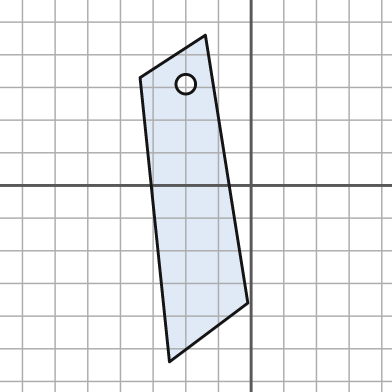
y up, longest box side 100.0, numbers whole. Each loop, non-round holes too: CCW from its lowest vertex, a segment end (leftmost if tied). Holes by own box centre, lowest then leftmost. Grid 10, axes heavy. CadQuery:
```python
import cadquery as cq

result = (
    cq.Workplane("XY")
    .moveTo(-25.0, -54.0)
    .lineTo(-1.0, -36.0)
    .lineTo(-14.0, 46.0)
    .lineTo(-34.0, 33.0)
    .close()
    .moveTo(-20.0, 31.0)
    .circle(3.0)
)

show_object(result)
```